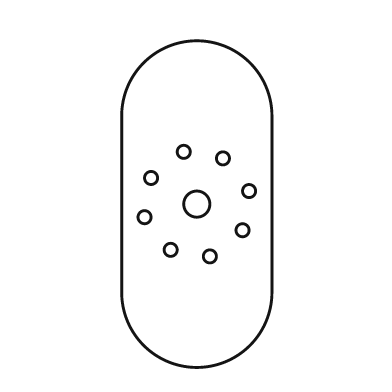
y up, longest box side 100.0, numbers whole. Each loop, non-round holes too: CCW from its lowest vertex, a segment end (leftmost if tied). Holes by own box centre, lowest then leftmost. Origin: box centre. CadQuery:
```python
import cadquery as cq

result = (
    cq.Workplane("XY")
    .moveTo(-23.0, -27.0)
    .threePointArc((0.0, -50.0), (23.0, -27.0))
    .lineTo(23.0, 27.0)
    .threePointArc((0.0, 50.0), (-23.0, 27.0))
    .close()
    .moveTo(4.0, -16.0)
    .circle(2.0)
    .moveTo(-8.0, -14.0)
    .circle(2.0)
    .moveTo(14.0, -8.0)
    .circle(2.0)
    .moveTo(-16.0, -4.0)
    .circle(2.0)
    .moveTo(0.0, 0.0)
    .circle(4.0)
    .moveTo(16.0, 4.0)
    .circle(2.0)
    .moveTo(-14.0, 8.0)
    .circle(2.0)
    .moveTo(8.0, 14.0)
    .circle(2.0)
    .moveTo(-4.0, 16.0)
    .circle(2.0)
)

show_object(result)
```